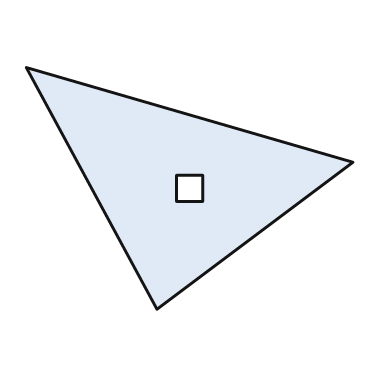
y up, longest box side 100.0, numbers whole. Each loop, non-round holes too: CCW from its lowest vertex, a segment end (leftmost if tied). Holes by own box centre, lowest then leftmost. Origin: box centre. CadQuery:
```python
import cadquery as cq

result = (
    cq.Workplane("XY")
    .moveTo(-10.0, -37.0)
    .lineTo(50.0, 8.0)
    .lineTo(-50.0, 37.0)
    .close()
    .moveTo(-4.0, -4.0)
    .lineTo(4.0, -4.0)
    .lineTo(4.0, 4.0)
    .lineTo(-4.0, 4.0)
    .close()
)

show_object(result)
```